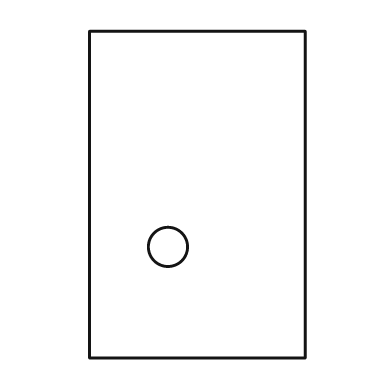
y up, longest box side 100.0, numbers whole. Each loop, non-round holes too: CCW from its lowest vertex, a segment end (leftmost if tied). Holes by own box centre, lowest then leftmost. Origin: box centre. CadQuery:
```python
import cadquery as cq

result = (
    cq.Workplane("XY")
    .moveTo(-33.0, -50.0)
    .lineTo(33.0, -50.0)
    .lineTo(33.0, 50.0)
    .lineTo(-33.0, 50.0)
    .close()
    .moveTo(-9.0, -16.0)
    .circle(6.0)
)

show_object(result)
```